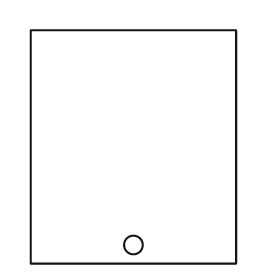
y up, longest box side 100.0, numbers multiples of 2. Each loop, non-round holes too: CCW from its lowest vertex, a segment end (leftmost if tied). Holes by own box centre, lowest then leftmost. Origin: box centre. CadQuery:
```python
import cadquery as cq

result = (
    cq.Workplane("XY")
    .moveTo(-44.0, -50.0)
    .lineTo(44.0, -50.0)
    .lineTo(44.0, 50.0)
    .lineTo(-44.0, 50.0)
    .close()
    .moveTo(0.0, -42.0)
    .circle(4.0)
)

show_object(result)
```